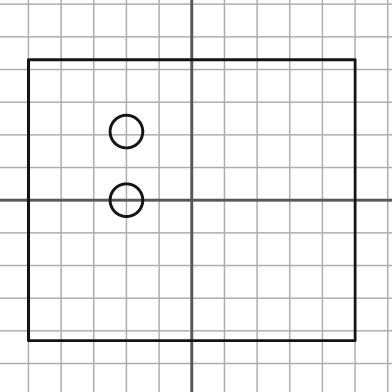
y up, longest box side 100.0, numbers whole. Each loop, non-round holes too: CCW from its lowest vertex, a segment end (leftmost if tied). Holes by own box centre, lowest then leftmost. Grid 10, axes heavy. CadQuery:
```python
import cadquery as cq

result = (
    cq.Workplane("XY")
    .moveTo(-50.0, -43.0)
    .lineTo(50.0, -43.0)
    .lineTo(50.0, 43.0)
    .lineTo(-50.0, 43.0)
    .close()
    .moveTo(-20.0, 0.0)
    .circle(5.0)
    .moveTo(-20.0, 21.0)
    .circle(5.0)
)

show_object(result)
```